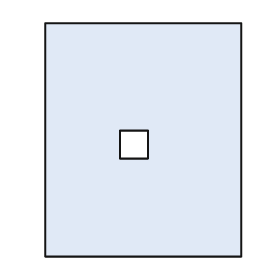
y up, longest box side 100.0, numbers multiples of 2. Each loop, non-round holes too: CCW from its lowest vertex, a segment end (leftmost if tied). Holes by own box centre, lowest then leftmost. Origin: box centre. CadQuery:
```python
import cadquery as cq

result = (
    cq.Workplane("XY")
    .moveTo(-42.0, -50.0)
    .lineTo(42.0, -50.0)
    .lineTo(42.0, 50.0)
    .lineTo(-42.0, 50.0)
    .close()
    .moveTo(-10.0, -8.0)
    .lineTo(2.0, -8.0)
    .lineTo(2.0, 4.0)
    .lineTo(-10.0, 4.0)
    .close()
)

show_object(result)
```